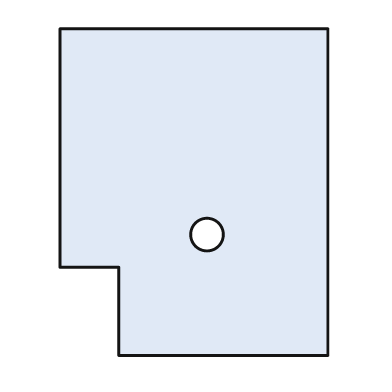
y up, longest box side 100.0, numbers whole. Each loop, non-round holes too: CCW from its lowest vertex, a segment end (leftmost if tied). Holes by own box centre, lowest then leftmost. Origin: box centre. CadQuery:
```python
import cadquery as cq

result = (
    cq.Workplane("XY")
    .moveTo(-23.0, -50.0)
    .lineTo(41.0, -50.0)
    .lineTo(41.0, 50.0)
    .lineTo(-41.0, 50.0)
    .lineTo(-41.0, -23.0)
    .lineTo(-23.0, -23.0)
    .close()
    .moveTo(4.0, -13.0)
    .circle(5.0)
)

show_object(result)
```